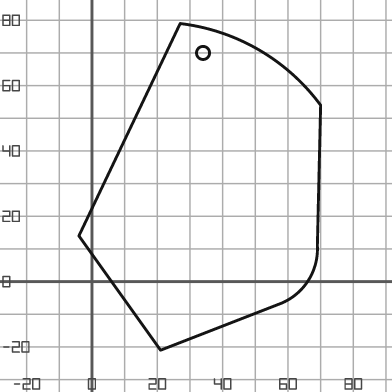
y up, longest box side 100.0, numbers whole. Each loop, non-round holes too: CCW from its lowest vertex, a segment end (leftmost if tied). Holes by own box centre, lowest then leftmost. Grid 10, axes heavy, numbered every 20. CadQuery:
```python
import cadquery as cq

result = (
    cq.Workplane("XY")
    .moveTo(21.0, -21.0)
    .lineTo(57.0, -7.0)
    .threePointArc((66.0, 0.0), (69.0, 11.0))
    .lineTo(70.0, 54.0)
    .threePointArc((51.0, 71.0), (27.0, 79.0))
    .lineTo(-4.0, 14.0)
    .close()
    .moveTo(34.0, 70.0)
    .circle(2.0)
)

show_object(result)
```